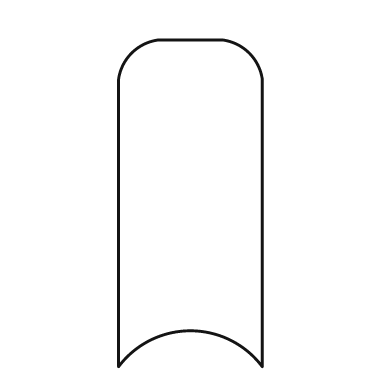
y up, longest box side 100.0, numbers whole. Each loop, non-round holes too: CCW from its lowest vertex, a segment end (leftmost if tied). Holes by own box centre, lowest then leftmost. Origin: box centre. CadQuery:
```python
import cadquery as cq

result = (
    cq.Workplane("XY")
    .moveTo(-22.0, -50.0)
    .threePointArc((0.0, -39.0), (22.0, -50.0))
    .lineTo(22.0, 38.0)
    .threePointArc((18.0, 46.0), (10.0, 50.0))
    .lineTo(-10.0, 50.0)
    .threePointArc((-18.0, 46.0), (-22.0, 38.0))
    .close()
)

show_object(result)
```